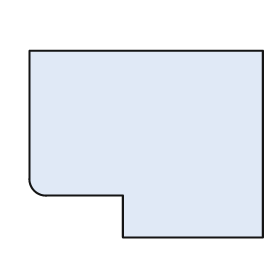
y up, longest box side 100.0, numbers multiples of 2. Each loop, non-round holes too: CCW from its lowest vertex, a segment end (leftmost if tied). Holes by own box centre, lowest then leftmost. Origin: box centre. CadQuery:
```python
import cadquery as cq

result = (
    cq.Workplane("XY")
    .moveTo(-10.0, -40.0)
    .lineTo(50.0, -40.0)
    .lineTo(50.0, 40.0)
    .lineTo(-50.0, 40.0)
    .lineTo(-50.0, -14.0)
    .threePointArc((-48.0, -20.0), (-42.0, -22.0))
    .lineTo(-10.0, -22.0)
    .close()
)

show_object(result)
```